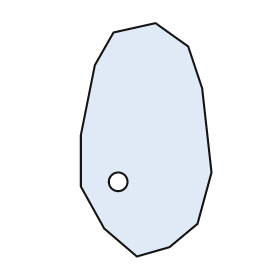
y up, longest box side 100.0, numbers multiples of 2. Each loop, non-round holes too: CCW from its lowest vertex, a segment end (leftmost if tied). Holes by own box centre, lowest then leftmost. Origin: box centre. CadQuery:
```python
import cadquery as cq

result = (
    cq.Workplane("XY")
    .moveTo(-4.0, -50.0)
    .lineTo(10.0, -46.0)
    .lineTo(22.0, -36.0)
    .lineTo(28.0, -14.0)
    .lineTo(24.0, 22.0)
    .lineTo(18.0, 40.0)
    .lineTo(4.0, 50.0)
    .lineTo(-14.0, 46.0)
    .lineTo(-22.0, 32.0)
    .lineTo(-28.0, 2.0)
    .lineTo(-28.0, -20.0)
    .lineTo(-18.0, -38.0)
    .close()
    .moveTo(-12.0, -18.0)
    .circle(4.0)
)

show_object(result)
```